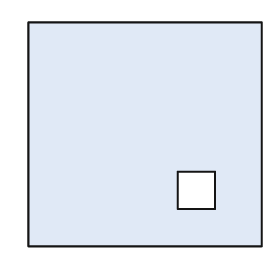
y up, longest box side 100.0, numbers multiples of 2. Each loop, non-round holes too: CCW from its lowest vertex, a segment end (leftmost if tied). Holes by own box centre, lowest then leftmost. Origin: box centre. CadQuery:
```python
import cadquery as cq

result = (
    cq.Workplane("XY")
    .moveTo(-50.0, -48.0)
    .lineTo(50.0, -48.0)
    .lineTo(50.0, 48.0)
    .lineTo(-50.0, 48.0)
    .close()
    .moveTo(14.0, -32.0)
    .lineTo(30.0, -32.0)
    .lineTo(30.0, -16.0)
    .lineTo(14.0, -16.0)
    .close()
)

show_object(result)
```